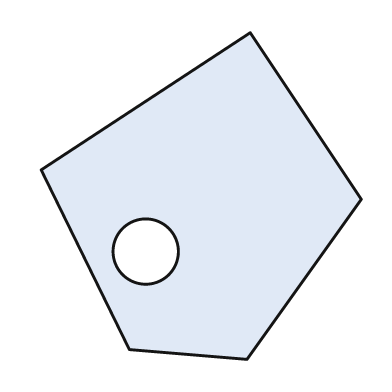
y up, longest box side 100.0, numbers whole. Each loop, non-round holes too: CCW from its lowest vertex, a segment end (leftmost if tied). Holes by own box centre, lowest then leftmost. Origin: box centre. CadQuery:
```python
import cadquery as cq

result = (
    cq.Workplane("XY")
    .moveTo(14.0, -50.0)
    .lineTo(49.0, -1.0)
    .lineTo(15.0, 50.0)
    .lineTo(-49.0, 8.0)
    .lineTo(-22.0, -47.0)
    .close()
    .moveTo(-17.0, -17.0)
    .circle(10.0)
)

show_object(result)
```